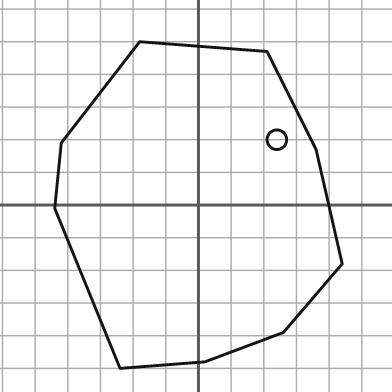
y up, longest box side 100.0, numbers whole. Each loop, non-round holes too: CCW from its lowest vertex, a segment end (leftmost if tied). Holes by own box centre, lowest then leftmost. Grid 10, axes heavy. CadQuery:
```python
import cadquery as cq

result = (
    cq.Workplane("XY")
    .moveTo(-24.0, -50.0)
    .lineTo(2.0, -48.0)
    .lineTo(26.0, -39.0)
    .lineTo(44.0, -18.0)
    .lineTo(36.0, 17.0)
    .lineTo(21.0, 47.0)
    .lineTo(-18.0, 50.0)
    .lineTo(-42.0, 19.0)
    .lineTo(-44.0, -1.0)
    .close()
    .moveTo(24.0, 20.0)
    .circle(3.0)
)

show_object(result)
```